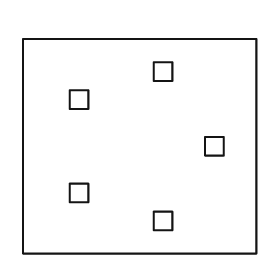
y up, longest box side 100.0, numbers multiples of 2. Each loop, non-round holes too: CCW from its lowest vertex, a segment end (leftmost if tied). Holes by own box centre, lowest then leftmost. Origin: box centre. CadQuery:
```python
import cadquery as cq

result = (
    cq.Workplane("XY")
    .moveTo(-50.0, -46.0)
    .lineTo(50.0, -46.0)
    .lineTo(50.0, 46.0)
    .lineTo(-50.0, 46.0)
    .close()
    .moveTo(6.0, -36.0)
    .lineTo(14.0, -36.0)
    .lineTo(14.0, -28.0)
    .lineTo(6.0, -28.0)
    .close()
    .moveTo(-30.0, -24.0)
    .lineTo(-22.0, -24.0)
    .lineTo(-22.0, -16.0)
    .lineTo(-30.0, -16.0)
    .close()
    .moveTo(28.0, -4.0)
    .lineTo(36.0, -4.0)
    .lineTo(36.0, 4.0)
    .lineTo(28.0, 4.0)
    .close()
    .moveTo(-30.0, 16.0)
    .lineTo(-22.0, 16.0)
    .lineTo(-22.0, 24.0)
    .lineTo(-30.0, 24.0)
    .close()
    .moveTo(6.0, 28.0)
    .lineTo(14.0, 28.0)
    .lineTo(14.0, 36.0)
    .lineTo(6.0, 36.0)
    .close()
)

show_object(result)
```